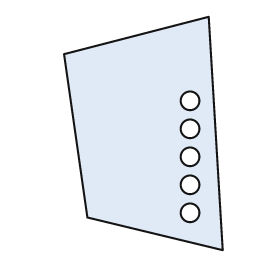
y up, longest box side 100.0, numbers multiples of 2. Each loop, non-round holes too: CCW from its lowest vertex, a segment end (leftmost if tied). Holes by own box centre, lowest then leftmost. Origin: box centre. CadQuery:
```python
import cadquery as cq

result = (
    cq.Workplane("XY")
    .moveTo(34.0, -50.0)
    .lineTo(28.0, 50.0)
    .lineTo(-34.0, 34.0)
    .lineTo(-24.0, -36.0)
    .close()
    .moveTo(20.0, -34.0)
    .circle(4.0)
    .moveTo(20.0, -22.0)
    .circle(4.0)
    .moveTo(20.0, -10.0)
    .circle(4.0)
    .moveTo(20.0, 2.0)
    .circle(4.0)
    .moveTo(20.0, 14.0)
    .circle(4.0)
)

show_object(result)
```